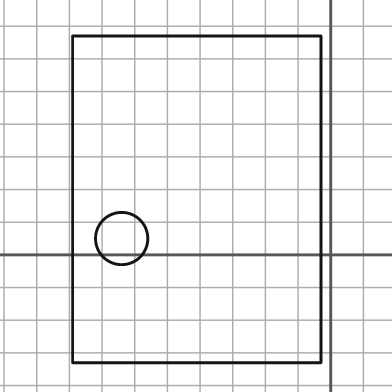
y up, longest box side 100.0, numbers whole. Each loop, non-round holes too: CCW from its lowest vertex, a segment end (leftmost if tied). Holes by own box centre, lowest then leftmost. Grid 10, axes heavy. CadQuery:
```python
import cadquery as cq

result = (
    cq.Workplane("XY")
    .moveTo(-79.0, -33.0)
    .lineTo(-3.0, -33.0)
    .lineTo(-3.0, 67.0)
    .lineTo(-79.0, 67.0)
    .close()
    .moveTo(-64.0, 5.0)
    .circle(8.0)
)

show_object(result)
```